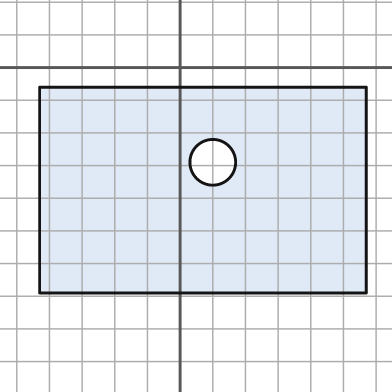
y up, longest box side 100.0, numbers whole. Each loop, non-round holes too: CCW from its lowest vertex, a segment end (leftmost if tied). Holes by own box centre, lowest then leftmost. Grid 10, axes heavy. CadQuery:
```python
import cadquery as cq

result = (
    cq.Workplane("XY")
    .moveTo(-43.0, -69.0)
    .lineTo(57.0, -69.0)
    .lineTo(57.0, -6.0)
    .lineTo(-43.0, -6.0)
    .close()
    .moveTo(10.0, -29.0)
    .circle(7.0)
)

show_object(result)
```